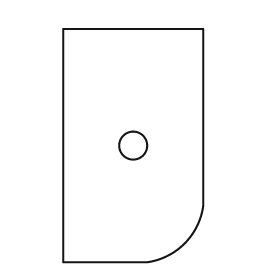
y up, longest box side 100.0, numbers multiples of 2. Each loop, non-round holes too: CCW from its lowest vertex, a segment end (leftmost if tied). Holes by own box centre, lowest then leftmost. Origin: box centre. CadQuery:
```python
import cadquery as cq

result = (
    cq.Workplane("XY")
    .moveTo(-30.0, -50.0)
    .lineTo(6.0, -50.0)
    .threePointArc((22.0, -42.0), (30.0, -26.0))
    .lineTo(30.0, 50.0)
    .lineTo(-30.0, 50.0)
    .close()
    .moveTo(0.0, 0.0)
    .circle(6.0)
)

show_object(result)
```